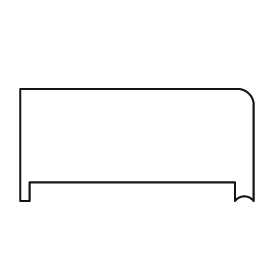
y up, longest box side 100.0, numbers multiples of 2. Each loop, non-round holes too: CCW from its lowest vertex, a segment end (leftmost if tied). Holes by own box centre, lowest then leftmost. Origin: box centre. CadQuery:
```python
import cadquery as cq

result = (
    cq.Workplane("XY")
    .moveTo(-50.0, -24.0)
    .lineTo(-46.0, -24.0)
    .lineTo(-46.0, -16.0)
    .lineTo(42.0, -16.0)
    .lineTo(42.0, -24.0)
    .threePointArc((46.0, -22.0), (50.0, -24.0))
    .lineTo(50.0, 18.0)
    .threePointArc((48.0, 22.0), (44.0, 24.0))
    .lineTo(-50.0, 24.0)
    .close()
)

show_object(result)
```